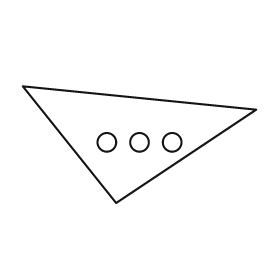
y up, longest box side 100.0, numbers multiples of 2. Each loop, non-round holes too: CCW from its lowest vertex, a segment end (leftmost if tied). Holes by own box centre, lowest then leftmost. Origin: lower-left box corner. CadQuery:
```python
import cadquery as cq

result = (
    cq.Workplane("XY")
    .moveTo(40.0, 0.0)
    .lineTo(100.0, 40.0)
    .lineTo(0.0, 50.0)
    .close()
    .moveTo(36.0, 26.0)
    .circle(4.0)
    .moveTo(50.0, 26.0)
    .circle(4.0)
    .moveTo(64.0, 26.0)
    .circle(4.0)
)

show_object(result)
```